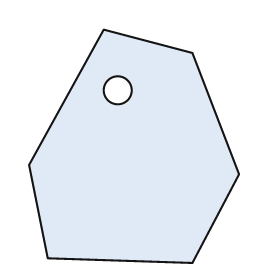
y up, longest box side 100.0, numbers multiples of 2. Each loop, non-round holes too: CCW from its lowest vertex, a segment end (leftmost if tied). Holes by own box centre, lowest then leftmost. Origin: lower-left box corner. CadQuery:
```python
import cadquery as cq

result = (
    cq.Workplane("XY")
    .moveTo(70.0, 0.0)
    .lineTo(90.0, 38.0)
    .lineTo(70.0, 90.0)
    .lineTo(32.0, 100.0)
    .lineTo(0.0, 42.0)
    .lineTo(8.0, 2.0)
    .close()
    .moveTo(38.0, 74.0)
    .circle(6.0)
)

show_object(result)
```